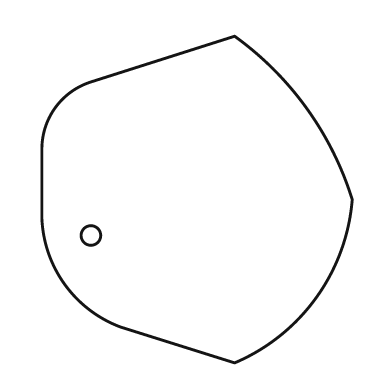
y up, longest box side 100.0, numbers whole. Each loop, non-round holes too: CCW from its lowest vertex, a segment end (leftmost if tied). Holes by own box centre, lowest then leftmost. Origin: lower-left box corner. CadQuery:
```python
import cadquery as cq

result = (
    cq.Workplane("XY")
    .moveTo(59.0, 0.0)
    .threePointArc((84.0, 20.0), (95.0, 50.0))
    .threePointArc((81.0, 78.0), (59.0, 100.0))
    .lineTo(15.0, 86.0)
    .threePointArc((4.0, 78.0), (0.0, 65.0))
    .lineTo(0.0, 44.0)
    .threePointArc((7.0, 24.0), (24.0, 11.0))
    .close()
    .moveTo(15.0, 39.0)
    .circle(3.0)
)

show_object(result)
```